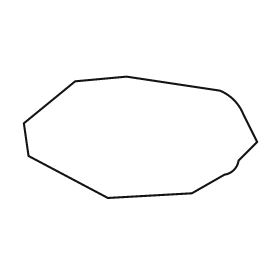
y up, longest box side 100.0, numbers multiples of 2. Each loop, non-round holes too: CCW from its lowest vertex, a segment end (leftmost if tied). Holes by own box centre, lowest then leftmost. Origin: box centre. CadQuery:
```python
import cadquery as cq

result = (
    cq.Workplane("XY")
    .moveTo(-14.0, -26.0)
    .lineTo(22.0, -24.0)
    .lineTo(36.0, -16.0)
    .threePointArc((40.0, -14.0), (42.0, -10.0))
    .lineTo(50.0, -2.0)
    .lineTo(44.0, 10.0)
    .threePointArc((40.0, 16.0), (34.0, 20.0))
    .lineTo(-6.0, 26.0)
    .lineTo(-28.0, 24.0)
    .lineTo(-50.0, 6.0)
    .lineTo(-48.0, -8.0)
    .close()
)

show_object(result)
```